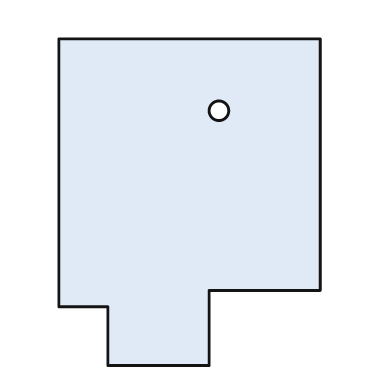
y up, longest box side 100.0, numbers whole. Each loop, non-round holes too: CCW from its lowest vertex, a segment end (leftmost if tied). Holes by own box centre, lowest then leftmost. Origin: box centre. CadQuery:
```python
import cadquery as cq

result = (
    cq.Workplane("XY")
    .moveTo(-25.0, -50.0)
    .lineTo(6.0, -50.0)
    .lineTo(6.0, -27.0)
    .lineTo(40.0, -27.0)
    .lineTo(40.0, 50.0)
    .lineTo(-40.0, 50.0)
    .lineTo(-40.0, -32.0)
    .lineTo(-25.0, -32.0)
    .close()
    .moveTo(9.0, 28.0)
    .circle(3.0)
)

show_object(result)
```